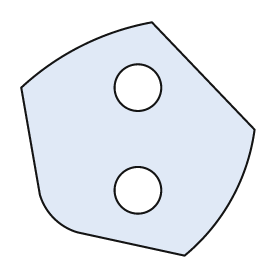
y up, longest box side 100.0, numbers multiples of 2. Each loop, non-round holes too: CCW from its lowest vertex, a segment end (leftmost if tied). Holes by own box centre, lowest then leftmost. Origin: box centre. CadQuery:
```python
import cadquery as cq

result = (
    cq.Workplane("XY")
    .moveTo(20.0, -50.0)
    .threePointArc((40.0, -26.0), (50.0, 4.0))
    .lineTo(6.0, 50.0)
    .threePointArc((-24.0, 40.0), (-50.0, 22.0))
    .lineTo(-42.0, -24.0)
    .threePointArc((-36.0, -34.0), (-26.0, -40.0))
    .close()
    .moveTo(0.0, -22.0)
    .circle(10.0)
    .moveTo(0.0, 22.0)
    .circle(10.0)
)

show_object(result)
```